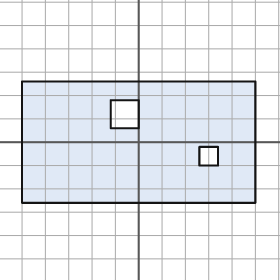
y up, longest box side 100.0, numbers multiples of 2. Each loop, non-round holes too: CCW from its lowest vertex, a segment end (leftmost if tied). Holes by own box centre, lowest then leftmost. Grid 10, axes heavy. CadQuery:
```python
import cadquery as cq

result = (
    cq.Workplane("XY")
    .moveTo(-50.0, -26.0)
    .lineTo(50.0, -26.0)
    .lineTo(50.0, 26.0)
    .lineTo(-50.0, 26.0)
    .close()
    .moveTo(26.0, -10.0)
    .lineTo(34.0, -10.0)
    .lineTo(34.0, -2.0)
    .lineTo(26.0, -2.0)
    .close()
    .moveTo(-12.0, 6.0)
    .lineTo(0.0, 6.0)
    .lineTo(0.0, 18.0)
    .lineTo(-12.0, 18.0)
    .close()
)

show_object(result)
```